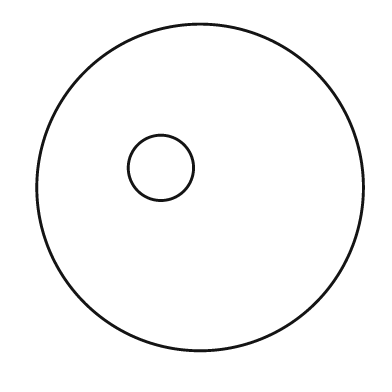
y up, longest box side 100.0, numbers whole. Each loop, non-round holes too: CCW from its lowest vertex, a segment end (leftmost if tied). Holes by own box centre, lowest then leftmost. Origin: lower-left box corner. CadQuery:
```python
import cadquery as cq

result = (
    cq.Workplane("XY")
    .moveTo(50.0, 50.0)
    .circle(50.0)
    .moveTo(38.0, 56.0)
    .circle(10.0)
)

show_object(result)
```